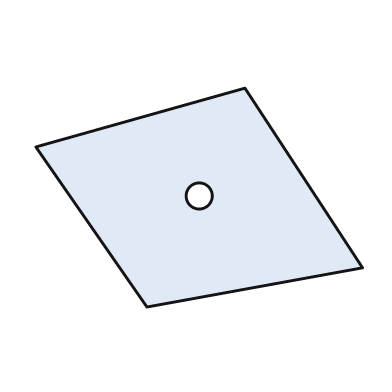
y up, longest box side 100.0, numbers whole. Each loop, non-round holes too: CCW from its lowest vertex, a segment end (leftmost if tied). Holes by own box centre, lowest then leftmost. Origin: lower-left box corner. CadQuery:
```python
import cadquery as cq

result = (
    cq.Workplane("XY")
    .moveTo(34.0, 0.0)
    .lineTo(100.0, 12.0)
    .lineTo(64.0, 67.0)
    .lineTo(0.0, 49.0)
    .close()
    .moveTo(50.0, 34.0)
    .circle(4.0)
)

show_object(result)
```